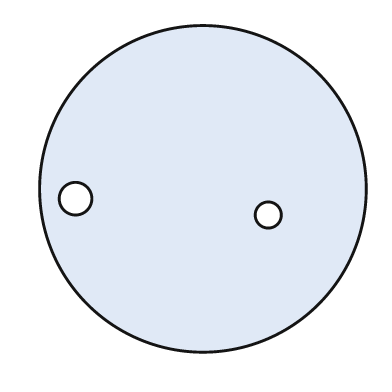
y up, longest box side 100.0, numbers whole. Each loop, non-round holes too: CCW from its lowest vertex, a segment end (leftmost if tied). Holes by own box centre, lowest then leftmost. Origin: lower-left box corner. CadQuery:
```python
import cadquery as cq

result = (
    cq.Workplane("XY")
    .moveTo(50.0, 50.0)
    .circle(50.0)
    .moveTo(70.0, 42.0)
    .circle(4.0)
    .moveTo(11.0, 47.0)
    .circle(5.0)
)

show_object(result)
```